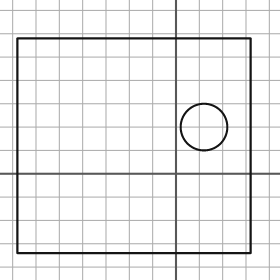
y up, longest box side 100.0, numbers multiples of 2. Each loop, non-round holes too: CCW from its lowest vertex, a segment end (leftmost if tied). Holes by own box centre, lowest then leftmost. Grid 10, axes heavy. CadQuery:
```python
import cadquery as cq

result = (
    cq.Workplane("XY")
    .moveTo(-68.0, -34.0)
    .lineTo(32.0, -34.0)
    .lineTo(32.0, 58.0)
    .lineTo(-68.0, 58.0)
    .close()
    .moveTo(12.0, 20.0)
    .circle(10.0)
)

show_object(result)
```